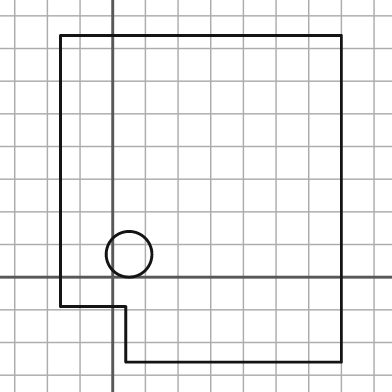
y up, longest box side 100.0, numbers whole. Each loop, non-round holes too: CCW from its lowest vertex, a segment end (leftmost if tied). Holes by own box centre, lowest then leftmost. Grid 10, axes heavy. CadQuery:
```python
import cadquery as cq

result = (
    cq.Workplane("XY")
    .moveTo(4.0, -26.0)
    .lineTo(70.0, -26.0)
    .lineTo(70.0, 74.0)
    .lineTo(-16.0, 74.0)
    .lineTo(-16.0, -9.0)
    .lineTo(4.0, -9.0)
    .close()
    .moveTo(5.0, 7.0)
    .circle(7.0)
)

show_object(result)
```